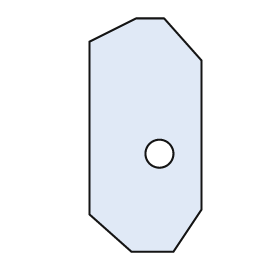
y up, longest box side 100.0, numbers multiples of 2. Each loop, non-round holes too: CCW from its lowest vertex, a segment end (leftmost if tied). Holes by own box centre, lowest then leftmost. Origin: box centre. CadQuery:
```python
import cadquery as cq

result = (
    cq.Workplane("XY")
    .moveTo(-6.0, -50.0)
    .lineTo(12.0, -50.0)
    .lineTo(24.0, -32.0)
    .lineTo(24.0, 32.0)
    .lineTo(8.0, 50.0)
    .lineTo(-4.0, 50.0)
    .lineTo(-24.0, 40.0)
    .lineTo(-24.0, -34.0)
    .close()
    .moveTo(6.0, -8.0)
    .circle(6.0)
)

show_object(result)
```